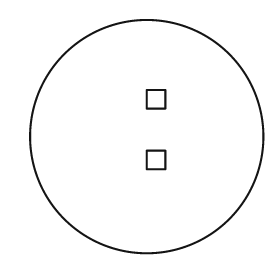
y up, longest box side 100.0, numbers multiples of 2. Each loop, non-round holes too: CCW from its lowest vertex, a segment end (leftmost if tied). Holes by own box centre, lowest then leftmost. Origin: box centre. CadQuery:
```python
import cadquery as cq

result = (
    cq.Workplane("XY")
    .moveTo(0.0, 0.0)
    .circle(50.0)
    .moveTo(0.0, -14.0)
    .lineTo(8.0, -14.0)
    .lineTo(8.0, -6.0)
    .lineTo(0.0, -6.0)
    .close()
    .moveTo(0.0, 12.0)
    .lineTo(8.0, 12.0)
    .lineTo(8.0, 20.0)
    .lineTo(0.0, 20.0)
    .close()
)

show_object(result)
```